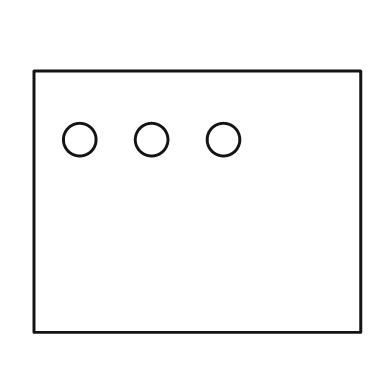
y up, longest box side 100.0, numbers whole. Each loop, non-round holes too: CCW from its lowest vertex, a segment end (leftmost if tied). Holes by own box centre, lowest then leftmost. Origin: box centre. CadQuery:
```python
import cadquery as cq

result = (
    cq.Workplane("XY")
    .moveTo(-50.0, -40.0)
    .lineTo(50.0, -40.0)
    .lineTo(50.0, 40.0)
    .lineTo(-50.0, 40.0)
    .close()
    .moveTo(-36.0, 19.0)
    .circle(5.0)
    .moveTo(-14.0, 19.0)
    .circle(5.0)
    .moveTo(8.0, 19.0)
    .circle(5.0)
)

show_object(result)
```